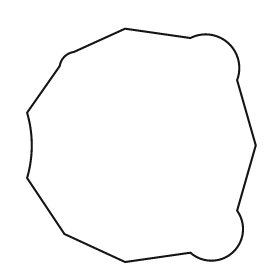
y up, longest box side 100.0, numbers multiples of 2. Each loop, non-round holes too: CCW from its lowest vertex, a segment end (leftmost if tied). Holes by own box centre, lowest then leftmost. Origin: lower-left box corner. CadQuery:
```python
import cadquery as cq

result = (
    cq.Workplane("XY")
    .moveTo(42.0, 0.0)
    .lineTo(70.0, 4.0)
    .threePointArc((88.0, 4.0), (90.0, 22.0))
    .lineTo(98.0, 50.0)
    .lineTo(90.0, 78.0)
    .threePointArc((86.0, 94.0), (70.0, 96.0))
    .lineTo(42.0, 100.0)
    .lineTo(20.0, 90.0)
    .threePointArc((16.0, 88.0), (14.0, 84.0))
    .lineTo(0.0, 64.0)
    .threePointArc((2.0, 50.0), (0.0, 36.0))
    .lineTo(16.0, 12.0)
    .close()
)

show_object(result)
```